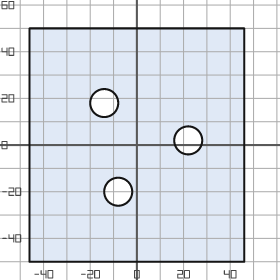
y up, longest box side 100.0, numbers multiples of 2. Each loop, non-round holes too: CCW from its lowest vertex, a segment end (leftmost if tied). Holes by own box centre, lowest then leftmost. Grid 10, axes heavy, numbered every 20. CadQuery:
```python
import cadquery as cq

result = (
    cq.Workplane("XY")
    .moveTo(-46.0, -50.0)
    .lineTo(46.0, -50.0)
    .lineTo(46.0, 50.0)
    .lineTo(-46.0, 50.0)
    .close()
    .moveTo(-8.0, -20.0)
    .circle(6.0)
    .moveTo(22.0, 2.0)
    .circle(6.0)
    .moveTo(-14.0, 18.0)
    .circle(6.0)
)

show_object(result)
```